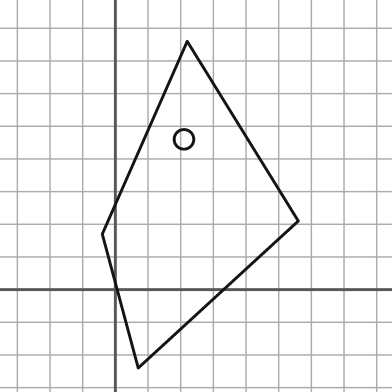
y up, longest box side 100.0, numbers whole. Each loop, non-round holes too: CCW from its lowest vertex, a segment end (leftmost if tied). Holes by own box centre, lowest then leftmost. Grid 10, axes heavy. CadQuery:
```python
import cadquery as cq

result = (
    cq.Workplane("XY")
    .moveTo(7.0, -24.0)
    .lineTo(56.0, 21.0)
    .lineTo(22.0, 76.0)
    .lineTo(-4.0, 17.0)
    .close()
    .moveTo(21.0, 46.0)
    .circle(3.0)
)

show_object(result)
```